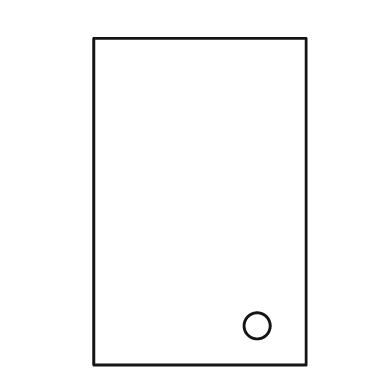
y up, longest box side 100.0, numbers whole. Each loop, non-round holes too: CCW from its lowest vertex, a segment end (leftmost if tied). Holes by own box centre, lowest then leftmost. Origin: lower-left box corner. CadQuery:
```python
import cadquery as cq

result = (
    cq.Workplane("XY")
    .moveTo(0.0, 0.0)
    .lineTo(65.0, 0.0)
    .lineTo(65.0, 100.0)
    .lineTo(0.0, 100.0)
    .close()
    .moveTo(50.0, 12.0)
    .circle(4.0)
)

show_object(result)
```